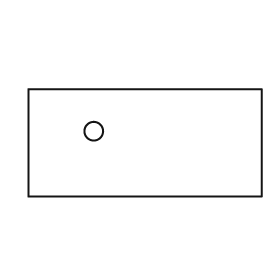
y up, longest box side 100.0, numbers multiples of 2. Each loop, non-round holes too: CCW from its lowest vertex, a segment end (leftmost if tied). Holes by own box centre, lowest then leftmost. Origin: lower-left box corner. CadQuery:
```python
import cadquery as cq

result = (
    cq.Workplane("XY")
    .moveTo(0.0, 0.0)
    .lineTo(100.0, 0.0)
    .lineTo(100.0, 46.0)
    .lineTo(0.0, 46.0)
    .close()
    .moveTo(28.0, 28.0)
    .circle(4.0)
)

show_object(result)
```